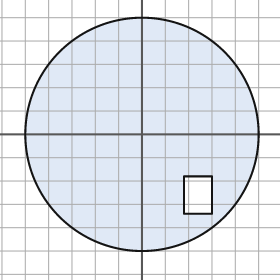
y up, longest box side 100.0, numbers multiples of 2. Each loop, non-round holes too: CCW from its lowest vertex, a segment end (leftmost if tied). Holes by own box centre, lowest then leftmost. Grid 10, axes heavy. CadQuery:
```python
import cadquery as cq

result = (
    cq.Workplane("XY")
    .moveTo(0.0, 0.0)
    .circle(50.0)
    .moveTo(18.0, -34.0)
    .lineTo(30.0, -34.0)
    .lineTo(30.0, -18.0)
    .lineTo(18.0, -18.0)
    .close()
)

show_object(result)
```